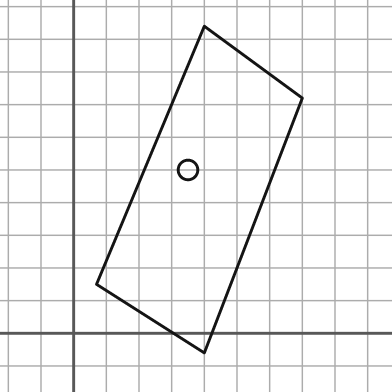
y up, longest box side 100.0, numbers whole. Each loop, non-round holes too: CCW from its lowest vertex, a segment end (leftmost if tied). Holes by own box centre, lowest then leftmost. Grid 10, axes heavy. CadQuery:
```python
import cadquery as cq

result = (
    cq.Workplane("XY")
    .moveTo(40.0, -6.0)
    .lineTo(70.0, 72.0)
    .lineTo(40.0, 94.0)
    .lineTo(7.0, 15.0)
    .close()
    .moveTo(35.0, 50.0)
    .circle(3.0)
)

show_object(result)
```